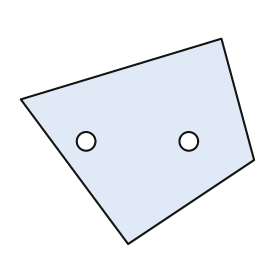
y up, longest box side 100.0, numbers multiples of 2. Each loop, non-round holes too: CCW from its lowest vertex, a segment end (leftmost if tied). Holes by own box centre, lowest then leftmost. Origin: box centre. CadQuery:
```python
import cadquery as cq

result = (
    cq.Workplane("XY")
    .moveTo(-4.0, -44.0)
    .lineTo(50.0, -8.0)
    .lineTo(36.0, 44.0)
    .lineTo(-50.0, 18.0)
    .close()
    .moveTo(-22.0, 0.0)
    .circle(4.0)
    .moveTo(22.0, 0.0)
    .circle(4.0)
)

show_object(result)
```